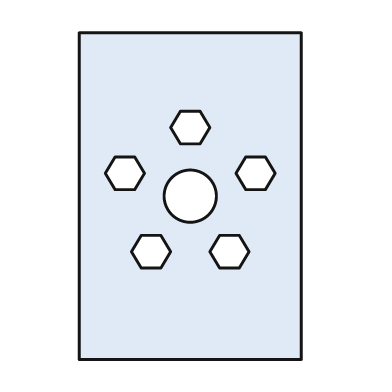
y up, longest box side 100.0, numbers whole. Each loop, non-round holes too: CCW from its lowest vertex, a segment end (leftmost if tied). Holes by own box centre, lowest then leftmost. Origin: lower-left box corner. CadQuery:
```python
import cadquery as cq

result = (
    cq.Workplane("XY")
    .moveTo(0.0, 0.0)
    .lineTo(68.0, 0.0)
    .lineTo(68.0, 100.0)
    .lineTo(0.0, 100.0)
    .close()
    .moveTo(19.0, 28.0)
    .lineTo(25.0, 28.0)
    .lineTo(28.0, 33.0)
    .lineTo(25.0, 38.0)
    .lineTo(19.0, 38.0)
    .lineTo(16.0, 33.0)
    .close()
    .moveTo(43.0, 28.0)
    .lineTo(49.0, 28.0)
    .lineTo(52.0, 33.0)
    .lineTo(49.0, 38.0)
    .lineTo(43.0, 38.0)
    .lineTo(40.0, 33.0)
    .close()
    .moveTo(34.0, 50.0)
    .circle(8.0)
    .moveTo(11.0, 52.0)
    .lineTo(17.0, 52.0)
    .lineTo(20.0, 57.0)
    .lineTo(17.0, 62.0)
    .lineTo(11.0, 62.0)
    .lineTo(8.0, 57.0)
    .close()
    .moveTo(51.0, 52.0)
    .lineTo(57.0, 52.0)
    .lineTo(60.0, 57.0)
    .lineTo(57.0, 62.0)
    .lineTo(51.0, 62.0)
    .lineTo(48.0, 57.0)
    .close()
    .moveTo(31.0, 66.0)
    .lineTo(37.0, 66.0)
    .lineTo(40.0, 71.0)
    .lineTo(37.0, 76.0)
    .lineTo(31.0, 76.0)
    .lineTo(28.0, 71.0)
    .close()
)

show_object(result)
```